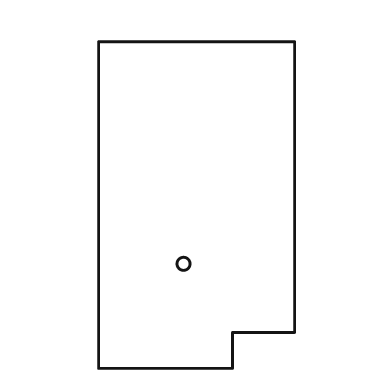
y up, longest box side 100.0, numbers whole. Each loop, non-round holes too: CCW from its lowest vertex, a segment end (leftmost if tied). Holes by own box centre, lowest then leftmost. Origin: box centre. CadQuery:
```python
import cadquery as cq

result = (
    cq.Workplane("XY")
    .moveTo(-30.0, -50.0)
    .lineTo(11.0, -50.0)
    .lineTo(11.0, -39.0)
    .lineTo(30.0, -39.0)
    .lineTo(30.0, 50.0)
    .lineTo(-30.0, 50.0)
    .close()
    .moveTo(-4.0, -18.0)
    .circle(2.0)
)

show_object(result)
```